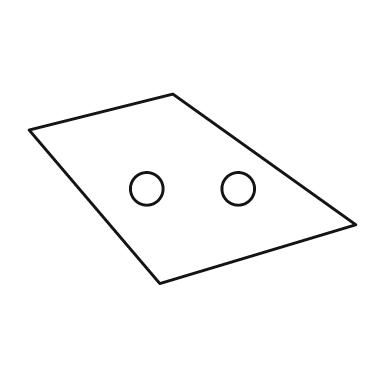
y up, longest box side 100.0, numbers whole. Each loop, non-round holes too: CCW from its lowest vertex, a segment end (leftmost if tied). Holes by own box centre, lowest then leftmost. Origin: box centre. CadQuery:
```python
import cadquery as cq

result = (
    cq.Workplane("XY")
    .moveTo(-10.0, -29.0)
    .lineTo(50.0, -11.0)
    .lineTo(-6.0, 29.0)
    .lineTo(-50.0, 18.0)
    .close()
    .moveTo(-14.0, 0.0)
    .circle(5.0)
    .moveTo(14.0, 0.0)
    .circle(5.0)
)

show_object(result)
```